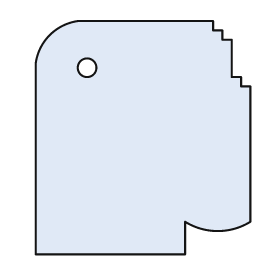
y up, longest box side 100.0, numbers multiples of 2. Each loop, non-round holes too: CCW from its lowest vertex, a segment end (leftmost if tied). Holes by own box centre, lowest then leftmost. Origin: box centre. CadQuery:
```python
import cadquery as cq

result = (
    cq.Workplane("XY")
    .moveTo(-46.0, -50.0)
    .lineTo(18.0, -50.0)
    .lineTo(18.0, -36.0)
    .threePointArc((32.0, -40.0), (46.0, -36.0))
    .lineTo(46.0, 22.0)
    .lineTo(42.0, 22.0)
    .lineTo(42.0, 26.0)
    .lineTo(38.0, 26.0)
    .lineTo(38.0, 42.0)
    .lineTo(34.0, 42.0)
    .lineTo(34.0, 46.0)
    .lineTo(30.0, 46.0)
    .lineTo(30.0, 50.0)
    .lineTo(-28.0, 50.0)
    .threePointArc((-40.0, 44.0), (-46.0, 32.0))
    .close()
    .moveTo(-24.0, 30.0)
    .circle(4.0)
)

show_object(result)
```